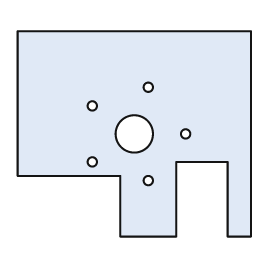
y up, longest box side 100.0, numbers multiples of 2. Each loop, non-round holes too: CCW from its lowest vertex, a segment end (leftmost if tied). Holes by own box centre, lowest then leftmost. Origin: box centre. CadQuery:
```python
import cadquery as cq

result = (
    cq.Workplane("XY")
    .moveTo(-6.0, -44.0)
    .lineTo(18.0, -44.0)
    .lineTo(18.0, -12.0)
    .lineTo(40.0, -12.0)
    .lineTo(40.0, -44.0)
    .lineTo(50.0, -44.0)
    .lineTo(50.0, 44.0)
    .lineTo(-50.0, 44.0)
    .lineTo(-50.0, -18.0)
    .lineTo(-6.0, -18.0)
    .close()
    .moveTo(6.0, -20.0)
    .circle(2.0)
    .moveTo(-18.0, -12.0)
    .circle(2.0)
    .moveTo(0.0, 0.0)
    .circle(8.0)
    .moveTo(22.0, 0.0)
    .circle(2.0)
    .moveTo(-18.0, 12.0)
    .circle(2.0)
    .moveTo(6.0, 20.0)
    .circle(2.0)
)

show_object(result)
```